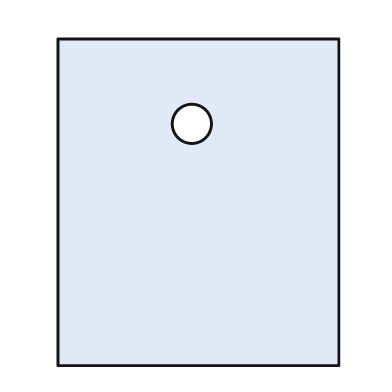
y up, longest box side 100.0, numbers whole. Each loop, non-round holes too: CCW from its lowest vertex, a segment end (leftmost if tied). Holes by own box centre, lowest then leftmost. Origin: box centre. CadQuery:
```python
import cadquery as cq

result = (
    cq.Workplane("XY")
    .moveTo(-43.0, -50.0)
    .lineTo(43.0, -50.0)
    .lineTo(43.0, 50.0)
    .lineTo(-43.0, 50.0)
    .close()
    .moveTo(-2.0, 24.0)
    .circle(6.0)
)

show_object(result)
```